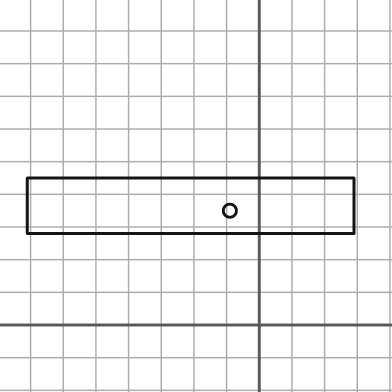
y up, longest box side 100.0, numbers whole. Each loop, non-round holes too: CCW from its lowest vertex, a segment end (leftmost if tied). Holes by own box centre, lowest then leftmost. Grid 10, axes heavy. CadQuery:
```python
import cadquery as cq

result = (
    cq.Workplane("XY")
    .moveTo(-71.0, 28.0)
    .lineTo(29.0, 28.0)
    .lineTo(29.0, 45.0)
    .lineTo(-71.0, 45.0)
    .close()
    .moveTo(-9.0, 35.0)
    .circle(2.0)
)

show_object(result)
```